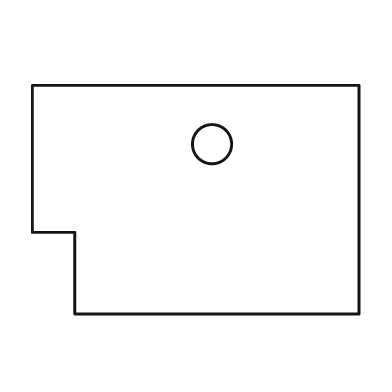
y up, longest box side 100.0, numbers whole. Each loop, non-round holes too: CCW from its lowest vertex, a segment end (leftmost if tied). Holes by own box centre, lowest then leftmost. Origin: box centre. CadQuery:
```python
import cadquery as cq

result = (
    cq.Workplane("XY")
    .moveTo(-37.0, -35.0)
    .lineTo(50.0, -35.0)
    .lineTo(50.0, 35.0)
    .lineTo(-50.0, 35.0)
    .lineTo(-50.0, -10.0)
    .lineTo(-37.0, -10.0)
    .close()
    .moveTo(5.0, 17.0)
    .circle(6.0)
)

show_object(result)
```